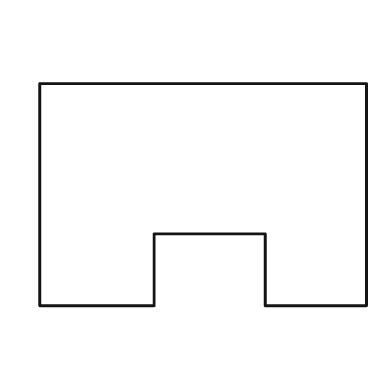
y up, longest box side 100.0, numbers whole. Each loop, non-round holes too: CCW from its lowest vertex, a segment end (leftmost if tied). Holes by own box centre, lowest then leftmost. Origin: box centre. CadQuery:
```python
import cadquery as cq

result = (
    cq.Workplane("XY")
    .moveTo(-50.0, -34.0)
    .lineTo(-15.0, -34.0)
    .lineTo(-15.0, -12.0)
    .lineTo(19.0, -12.0)
    .lineTo(19.0, -34.0)
    .lineTo(50.0, -34.0)
    .lineTo(50.0, 34.0)
    .lineTo(-50.0, 34.0)
    .close()
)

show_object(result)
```